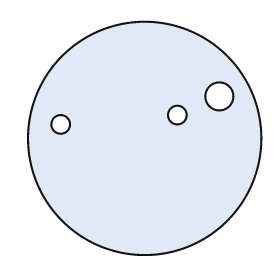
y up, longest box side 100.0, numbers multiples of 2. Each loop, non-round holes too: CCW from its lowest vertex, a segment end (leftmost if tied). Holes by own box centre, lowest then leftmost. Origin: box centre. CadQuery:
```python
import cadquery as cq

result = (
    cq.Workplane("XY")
    .moveTo(0.0, 0.0)
    .circle(50.0)
    .moveTo(-36.0, 6.0)
    .circle(4.0)
    .moveTo(14.0, 10.0)
    .circle(4.0)
    .moveTo(32.0, 18.0)
    .circle(6.0)
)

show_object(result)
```